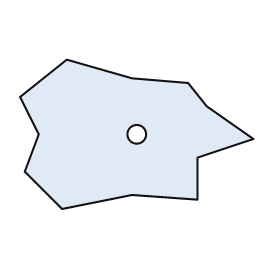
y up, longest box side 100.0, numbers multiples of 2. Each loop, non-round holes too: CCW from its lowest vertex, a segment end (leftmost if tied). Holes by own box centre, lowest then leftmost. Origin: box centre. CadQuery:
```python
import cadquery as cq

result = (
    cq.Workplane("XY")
    .moveTo(-32.0, -32.0)
    .lineTo(-2.0, -26.0)
    .lineTo(26.0, -28.0)
    .lineTo(26.0, -10.0)
    .lineTo(50.0, -2.0)
    .lineTo(30.0, 12.0)
    .lineTo(22.0, 22.0)
    .lineTo(-2.0, 24.0)
    .lineTo(-30.0, 32.0)
    .lineTo(-50.0, 16.0)
    .lineTo(-42.0, 0.0)
    .lineTo(-48.0, -16.0)
    .close()
    .moveTo(0.0, 0.0)
    .circle(4.0)
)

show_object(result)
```